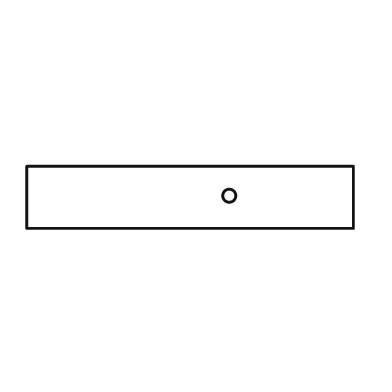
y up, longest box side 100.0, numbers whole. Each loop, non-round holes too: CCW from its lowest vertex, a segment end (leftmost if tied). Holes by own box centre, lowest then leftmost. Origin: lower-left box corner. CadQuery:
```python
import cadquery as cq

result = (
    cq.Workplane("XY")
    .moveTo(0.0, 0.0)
    .lineTo(100.0, 0.0)
    .lineTo(100.0, 19.0)
    .lineTo(0.0, 19.0)
    .close()
    .moveTo(62.0, 10.0)
    .circle(2.0)
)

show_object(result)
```